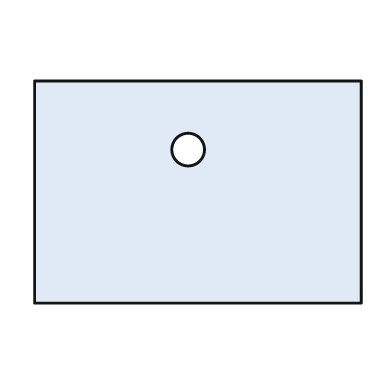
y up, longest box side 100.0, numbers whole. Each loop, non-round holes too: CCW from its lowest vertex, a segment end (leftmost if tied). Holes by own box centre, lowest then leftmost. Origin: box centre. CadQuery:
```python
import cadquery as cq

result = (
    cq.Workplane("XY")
    .moveTo(-50.0, -34.0)
    .lineTo(50.0, -34.0)
    .lineTo(50.0, 34.0)
    .lineTo(-50.0, 34.0)
    .close()
    .moveTo(-3.0, 13.0)
    .circle(5.0)
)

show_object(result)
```